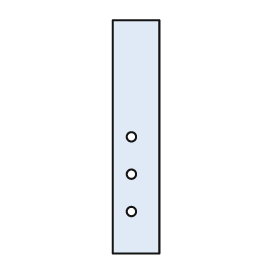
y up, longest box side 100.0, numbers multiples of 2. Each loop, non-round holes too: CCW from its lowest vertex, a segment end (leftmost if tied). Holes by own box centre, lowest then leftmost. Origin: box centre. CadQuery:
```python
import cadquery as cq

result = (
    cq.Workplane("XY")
    .moveTo(-10.0, -50.0)
    .lineTo(10.0, -50.0)
    .lineTo(10.0, 50.0)
    .lineTo(-10.0, 50.0)
    .close()
    .moveTo(-2.0, -32.0)
    .circle(2.0)
    .moveTo(-2.0, -16.0)
    .circle(2.0)
    .moveTo(-2.0, 0.0)
    .circle(2.0)
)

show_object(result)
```